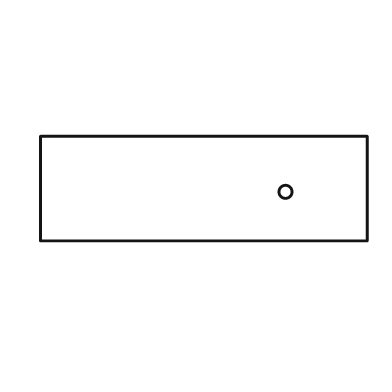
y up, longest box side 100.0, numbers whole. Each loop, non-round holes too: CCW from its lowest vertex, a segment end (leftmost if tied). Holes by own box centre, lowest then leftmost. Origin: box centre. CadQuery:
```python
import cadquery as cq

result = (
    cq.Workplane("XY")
    .moveTo(-50.0, -16.0)
    .lineTo(50.0, -16.0)
    .lineTo(50.0, 16.0)
    .lineTo(-50.0, 16.0)
    .close()
    .moveTo(25.0, -1.0)
    .circle(2.0)
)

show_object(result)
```